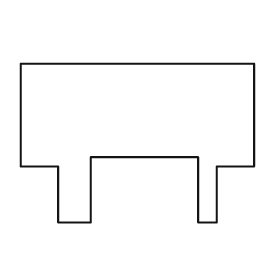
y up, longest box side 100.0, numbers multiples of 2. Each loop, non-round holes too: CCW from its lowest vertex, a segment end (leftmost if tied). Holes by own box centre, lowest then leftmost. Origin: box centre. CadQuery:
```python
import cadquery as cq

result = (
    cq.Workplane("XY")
    .moveTo(-34.0, -34.0)
    .lineTo(-20.0, -34.0)
    .lineTo(-20.0, -6.0)
    .lineTo(26.0, -6.0)
    .lineTo(26.0, -34.0)
    .lineTo(34.0, -34.0)
    .lineTo(34.0, -10.0)
    .lineTo(50.0, -10.0)
    .lineTo(50.0, 34.0)
    .lineTo(-50.0, 34.0)
    .lineTo(-50.0, -10.0)
    .lineTo(-34.0, -10.0)
    .close()
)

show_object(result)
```